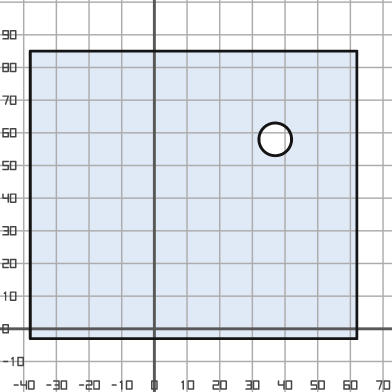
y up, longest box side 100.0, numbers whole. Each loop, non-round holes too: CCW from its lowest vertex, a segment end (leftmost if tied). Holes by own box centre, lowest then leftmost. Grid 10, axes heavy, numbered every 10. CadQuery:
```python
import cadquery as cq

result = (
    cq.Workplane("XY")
    .moveTo(-38.0, -3.0)
    .lineTo(62.0, -3.0)
    .lineTo(62.0, 85.0)
    .lineTo(-38.0, 85.0)
    .close()
    .moveTo(37.0, 58.0)
    .circle(5.0)
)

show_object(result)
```